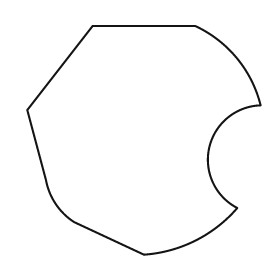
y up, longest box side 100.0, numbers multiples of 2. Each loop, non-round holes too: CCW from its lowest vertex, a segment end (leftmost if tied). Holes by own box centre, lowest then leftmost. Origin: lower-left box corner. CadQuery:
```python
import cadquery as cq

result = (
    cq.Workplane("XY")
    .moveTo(50.0, 0.0)
    .threePointArc((72.0, 6.0), (90.0, 20.0))
    .threePointArc((78.0, 46.0), (100.0, 64.0))
    .threePointArc((90.0, 84.0), (72.0, 98.0))
    .lineTo(28.0, 98.0)
    .lineTo(0.0, 62.0)
    .lineTo(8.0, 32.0)
    .threePointArc((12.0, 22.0), (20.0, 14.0))
    .close()
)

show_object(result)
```